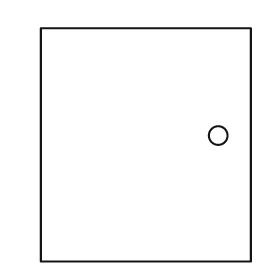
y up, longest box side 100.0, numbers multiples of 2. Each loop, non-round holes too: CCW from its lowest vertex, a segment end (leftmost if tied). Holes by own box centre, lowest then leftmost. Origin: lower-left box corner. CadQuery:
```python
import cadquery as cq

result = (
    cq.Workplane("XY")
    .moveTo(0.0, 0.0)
    .lineTo(90.0, 0.0)
    .lineTo(90.0, 100.0)
    .lineTo(0.0, 100.0)
    .close()
    .moveTo(76.0, 54.0)
    .circle(4.0)
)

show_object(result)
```